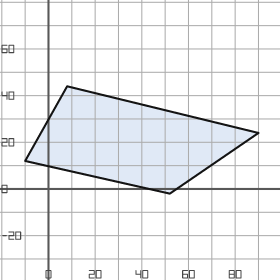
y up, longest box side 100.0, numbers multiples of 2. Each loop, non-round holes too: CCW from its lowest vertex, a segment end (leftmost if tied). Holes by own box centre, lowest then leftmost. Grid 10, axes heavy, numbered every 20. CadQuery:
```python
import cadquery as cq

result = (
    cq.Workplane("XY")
    .moveTo(52.0, -2.0)
    .lineTo(90.0, 24.0)
    .lineTo(8.0, 44.0)
    .lineTo(-10.0, 12.0)
    .close()
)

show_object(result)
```